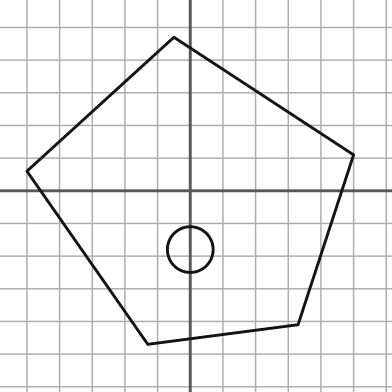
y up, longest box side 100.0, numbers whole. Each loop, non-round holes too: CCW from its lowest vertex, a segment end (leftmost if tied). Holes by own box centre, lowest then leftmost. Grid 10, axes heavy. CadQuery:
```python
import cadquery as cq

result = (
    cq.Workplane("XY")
    .moveTo(-13.0, -47.0)
    .lineTo(33.0, -41.0)
    .lineTo(50.0, 11.0)
    .lineTo(-5.0, 47.0)
    .lineTo(-50.0, 6.0)
    .close()
    .moveTo(0.0, -18.0)
    .circle(7.0)
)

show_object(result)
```